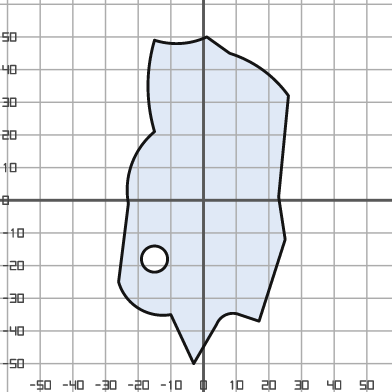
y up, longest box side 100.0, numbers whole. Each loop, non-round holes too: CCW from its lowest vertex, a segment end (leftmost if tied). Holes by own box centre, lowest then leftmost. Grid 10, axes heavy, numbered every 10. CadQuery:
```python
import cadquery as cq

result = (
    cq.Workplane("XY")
    .moveTo(-3.0, -50.0)
    .lineTo(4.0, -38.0)
    .threePointArc((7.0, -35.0), (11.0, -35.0))
    .lineTo(17.0, -37.0)
    .lineTo(25.0, -12.0)
    .lineTo(23.0, 1.0)
    .lineTo(26.0, 32.0)
    .threePointArc((18.0, 40.0), (8.0, 45.0))
    .lineTo(1.0, 50.0)
    .threePointArc((-7.0, 48.0), (-15.0, 49.0))
    .threePointArc((-17.0, 35.0), (-15.0, 21.0))
    .threePointArc((-22.0, 11.0), (-23.0, -1.0))
    .lineTo(-26.0, -25.0)
    .threePointArc((-20.0, -33.0), (-10.0, -35.0))
    .close()
    .moveTo(-15.0, -18.0)
    .circle(4.0)
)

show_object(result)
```